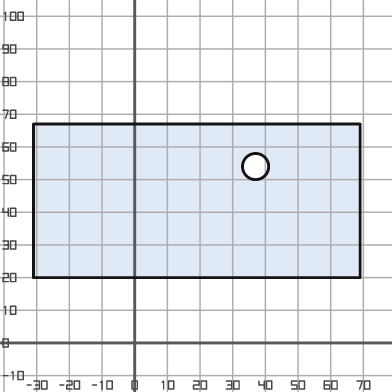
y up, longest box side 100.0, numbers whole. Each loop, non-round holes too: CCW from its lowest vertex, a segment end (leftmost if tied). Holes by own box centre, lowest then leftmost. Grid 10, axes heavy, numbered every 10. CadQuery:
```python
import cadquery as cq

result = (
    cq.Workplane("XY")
    .moveTo(-31.0, 20.0)
    .lineTo(69.0, 20.0)
    .lineTo(69.0, 67.0)
    .lineTo(-31.0, 67.0)
    .close()
    .moveTo(37.0, 54.0)
    .circle(4.0)
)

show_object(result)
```